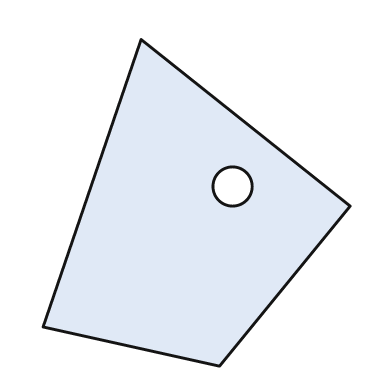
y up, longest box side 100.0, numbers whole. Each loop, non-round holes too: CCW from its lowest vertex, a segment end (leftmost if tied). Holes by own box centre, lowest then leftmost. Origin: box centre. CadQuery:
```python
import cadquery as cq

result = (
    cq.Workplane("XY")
    .moveTo(7.0, -50.0)
    .lineTo(47.0, -1.0)
    .lineTo(-17.0, 50.0)
    .lineTo(-47.0, -38.0)
    .close()
    .moveTo(11.0, 5.0)
    .circle(6.0)
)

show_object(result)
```